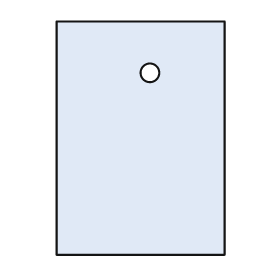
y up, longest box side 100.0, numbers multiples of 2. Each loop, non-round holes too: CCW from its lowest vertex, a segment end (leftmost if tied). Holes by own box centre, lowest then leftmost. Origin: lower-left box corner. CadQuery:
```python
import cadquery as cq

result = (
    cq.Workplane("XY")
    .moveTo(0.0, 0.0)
    .lineTo(72.0, 0.0)
    .lineTo(72.0, 100.0)
    .lineTo(0.0, 100.0)
    .close()
    .moveTo(40.0, 78.0)
    .circle(4.0)
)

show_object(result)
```